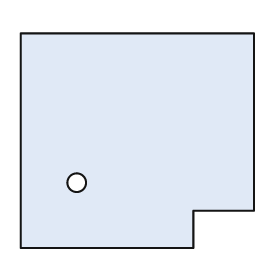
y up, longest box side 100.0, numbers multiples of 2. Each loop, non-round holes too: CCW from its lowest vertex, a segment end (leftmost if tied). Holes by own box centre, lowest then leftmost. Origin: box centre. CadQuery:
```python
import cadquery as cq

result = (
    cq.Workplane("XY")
    .moveTo(-50.0, -46.0)
    .lineTo(24.0, -46.0)
    .lineTo(24.0, -30.0)
    .lineTo(50.0, -30.0)
    .lineTo(50.0, 46.0)
    .lineTo(-50.0, 46.0)
    .close()
    .moveTo(-26.0, -18.0)
    .circle(4.0)
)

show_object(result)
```